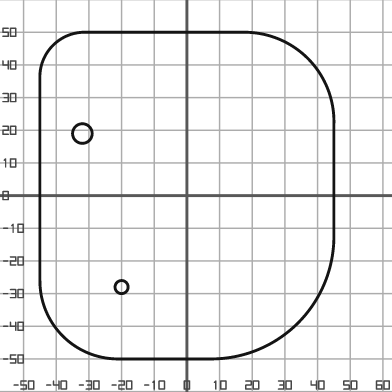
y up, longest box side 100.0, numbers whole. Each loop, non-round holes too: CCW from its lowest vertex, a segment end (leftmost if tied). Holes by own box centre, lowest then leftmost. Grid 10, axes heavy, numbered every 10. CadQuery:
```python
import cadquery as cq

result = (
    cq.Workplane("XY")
    .moveTo(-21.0, -50.0)
    .lineTo(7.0, -50.0)
    .threePointArc((34.0, -39.0), (45.0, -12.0))
    .lineTo(45.0, 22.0)
    .threePointArc((37.0, 42.0), (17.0, 50.0))
    .lineTo(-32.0, 50.0)
    .threePointArc((-41.0, 46.0), (-45.0, 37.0))
    .lineTo(-45.0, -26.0)
    .threePointArc((-38.0, -43.0), (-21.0, -50.0))
    .close()
    .moveTo(-20.0, -28.0)
    .circle(2.0)
    .moveTo(-32.0, 19.0)
    .circle(3.0)
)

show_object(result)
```